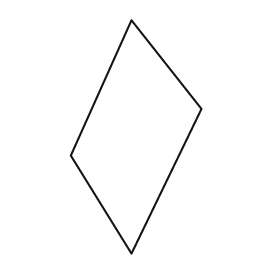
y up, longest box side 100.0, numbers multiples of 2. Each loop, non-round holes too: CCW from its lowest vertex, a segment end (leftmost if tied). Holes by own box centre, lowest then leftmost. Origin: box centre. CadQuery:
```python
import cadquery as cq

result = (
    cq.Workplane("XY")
    .moveTo(-2.0, -50.0)
    .lineTo(28.0, 12.0)
    .lineTo(-2.0, 50.0)
    .lineTo(-28.0, -8.0)
    .close()
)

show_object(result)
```